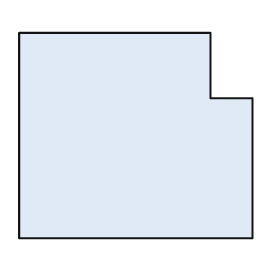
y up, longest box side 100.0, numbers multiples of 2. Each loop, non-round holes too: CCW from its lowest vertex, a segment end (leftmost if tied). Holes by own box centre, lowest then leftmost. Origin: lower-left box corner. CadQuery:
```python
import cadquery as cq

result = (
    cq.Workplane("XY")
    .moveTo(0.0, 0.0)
    .lineTo(100.0, 0.0)
    .lineTo(100.0, 60.0)
    .lineTo(82.0, 60.0)
    .lineTo(82.0, 88.0)
    .lineTo(0.0, 88.0)
    .close()
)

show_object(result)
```